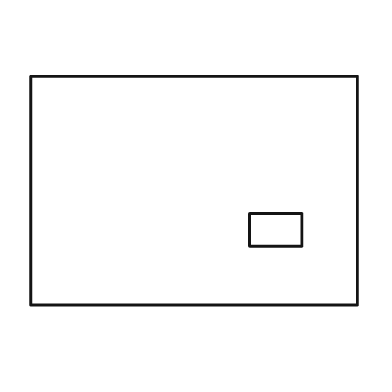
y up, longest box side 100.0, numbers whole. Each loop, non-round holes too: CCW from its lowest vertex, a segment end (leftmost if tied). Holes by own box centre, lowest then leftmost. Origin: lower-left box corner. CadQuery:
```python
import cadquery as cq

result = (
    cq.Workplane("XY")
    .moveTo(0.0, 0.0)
    .lineTo(100.0, 0.0)
    .lineTo(100.0, 70.0)
    .lineTo(0.0, 70.0)
    .close()
    .moveTo(67.0, 18.0)
    .lineTo(83.0, 18.0)
    .lineTo(83.0, 28.0)
    .lineTo(67.0, 28.0)
    .close()
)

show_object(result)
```